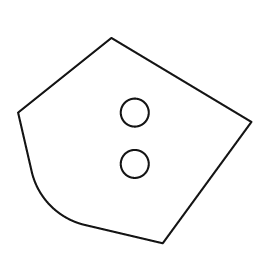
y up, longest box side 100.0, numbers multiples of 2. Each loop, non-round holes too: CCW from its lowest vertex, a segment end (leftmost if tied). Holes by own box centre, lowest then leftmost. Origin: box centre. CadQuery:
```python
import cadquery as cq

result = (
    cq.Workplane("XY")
    .moveTo(12.0, -44.0)
    .lineTo(50.0, 8.0)
    .lineTo(-10.0, 44.0)
    .lineTo(-50.0, 12.0)
    .lineTo(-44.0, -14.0)
    .threePointArc((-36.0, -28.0), (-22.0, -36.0))
    .close()
    .moveTo(0.0, -10.0)
    .circle(6.0)
    .moveTo(0.0, 12.0)
    .circle(6.0)
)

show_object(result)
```